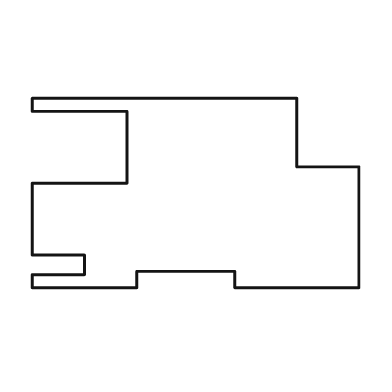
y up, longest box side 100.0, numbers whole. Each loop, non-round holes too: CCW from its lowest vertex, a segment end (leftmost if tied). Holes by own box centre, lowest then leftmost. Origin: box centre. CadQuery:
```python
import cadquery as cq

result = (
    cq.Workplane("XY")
    .moveTo(-50.0, -29.0)
    .lineTo(-18.0, -29.0)
    .lineTo(-18.0, -24.0)
    .lineTo(12.0, -24.0)
    .lineTo(12.0, -29.0)
    .lineTo(50.0, -29.0)
    .lineTo(50.0, 8.0)
    .lineTo(31.0, 8.0)
    .lineTo(31.0, 29.0)
    .lineTo(-50.0, 29.0)
    .lineTo(-50.0, 25.0)
    .lineTo(-21.0, 25.0)
    .lineTo(-21.0, 3.0)
    .lineTo(-50.0, 3.0)
    .lineTo(-50.0, -19.0)
    .lineTo(-34.0, -19.0)
    .lineTo(-34.0, -25.0)
    .lineTo(-50.0, -25.0)
    .close()
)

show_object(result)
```